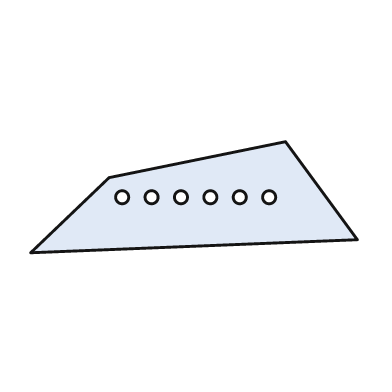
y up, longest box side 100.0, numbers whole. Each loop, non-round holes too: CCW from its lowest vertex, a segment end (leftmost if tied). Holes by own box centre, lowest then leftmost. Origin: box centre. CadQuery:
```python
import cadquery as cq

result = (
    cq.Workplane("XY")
    .moveTo(-50.0, -17.0)
    .lineTo(50.0, -13.0)
    .lineTo(28.0, 17.0)
    .lineTo(-26.0, 6.0)
    .close()
    .moveTo(-22.0, 0.0)
    .circle(2.0)
    .moveTo(-13.0, 0.0)
    .circle(2.0)
    .moveTo(-4.0, 0.0)
    .circle(2.0)
    .moveTo(5.0, 0.0)
    .circle(2.0)
    .moveTo(14.0, 0.0)
    .circle(2.0)
    .moveTo(23.0, 0.0)
    .circle(2.0)
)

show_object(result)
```